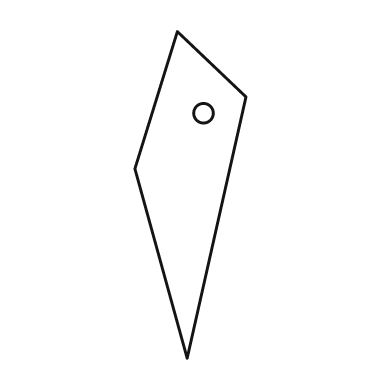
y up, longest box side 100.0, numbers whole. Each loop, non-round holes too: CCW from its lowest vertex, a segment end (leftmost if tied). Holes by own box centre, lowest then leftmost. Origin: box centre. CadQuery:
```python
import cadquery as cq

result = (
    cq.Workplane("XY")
    .moveTo(-1.0, -50.0)
    .lineTo(17.0, 30.0)
    .lineTo(-4.0, 50.0)
    .lineTo(-17.0, 8.0)
    .close()
    .moveTo(4.0, 25.0)
    .circle(3.0)
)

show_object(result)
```